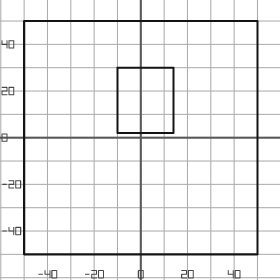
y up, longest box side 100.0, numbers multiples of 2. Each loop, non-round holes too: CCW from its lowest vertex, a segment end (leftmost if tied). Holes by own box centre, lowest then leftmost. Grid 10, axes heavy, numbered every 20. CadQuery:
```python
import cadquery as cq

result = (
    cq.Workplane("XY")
    .moveTo(-50.0, -50.0)
    .lineTo(50.0, -50.0)
    .lineTo(50.0, 50.0)
    .lineTo(-50.0, 50.0)
    .close()
    .moveTo(-10.0, 2.0)
    .lineTo(14.0, 2.0)
    .lineTo(14.0, 30.0)
    .lineTo(-10.0, 30.0)
    .close()
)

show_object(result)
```